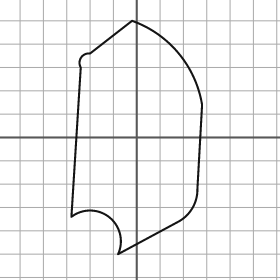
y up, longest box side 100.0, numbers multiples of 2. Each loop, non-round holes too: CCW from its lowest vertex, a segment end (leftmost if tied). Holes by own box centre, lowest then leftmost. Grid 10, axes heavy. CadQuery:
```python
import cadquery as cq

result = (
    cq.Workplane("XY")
    .moveTo(-8.0, -50.0)
    .lineTo(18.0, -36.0)
    .threePointArc((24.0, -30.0), (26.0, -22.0))
    .lineTo(28.0, 14.0)
    .threePointArc((18.0, 36.0), (-2.0, 50.0))
    .lineTo(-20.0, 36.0)
    .threePointArc((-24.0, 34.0), (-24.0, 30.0))
    .lineTo(-28.0, -34.0)
    .threePointArc((-12.0, -34.0), (-8.0, -50.0))
    .close()
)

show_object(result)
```